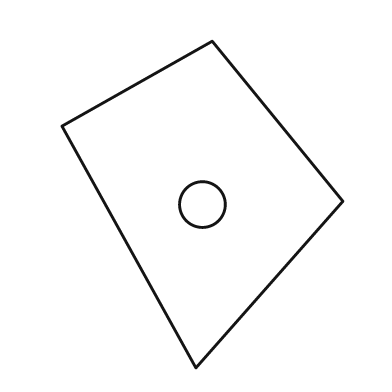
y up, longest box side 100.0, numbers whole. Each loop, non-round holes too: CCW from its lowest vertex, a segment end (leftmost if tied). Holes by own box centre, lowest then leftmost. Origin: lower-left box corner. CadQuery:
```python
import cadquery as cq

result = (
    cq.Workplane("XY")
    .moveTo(41.0, 0.0)
    .lineTo(86.0, 51.0)
    .lineTo(46.0, 100.0)
    .lineTo(0.0, 74.0)
    .close()
    .moveTo(43.0, 50.0)
    .circle(7.0)
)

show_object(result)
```